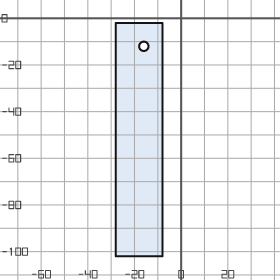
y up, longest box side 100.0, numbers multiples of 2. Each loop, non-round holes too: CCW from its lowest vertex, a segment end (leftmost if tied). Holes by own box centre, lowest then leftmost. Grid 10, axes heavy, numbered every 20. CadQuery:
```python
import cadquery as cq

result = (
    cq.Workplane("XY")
    .moveTo(-28.0, -102.0)
    .lineTo(-8.0, -102.0)
    .lineTo(-8.0, -2.0)
    .lineTo(-28.0, -2.0)
    .close()
    .moveTo(-16.0, -12.0)
    .circle(2.0)
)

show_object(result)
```